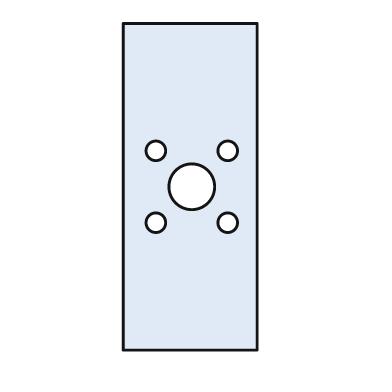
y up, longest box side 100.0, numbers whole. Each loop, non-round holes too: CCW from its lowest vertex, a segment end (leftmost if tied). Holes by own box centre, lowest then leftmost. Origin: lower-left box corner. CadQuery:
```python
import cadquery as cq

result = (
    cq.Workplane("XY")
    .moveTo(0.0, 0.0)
    .lineTo(41.0, 0.0)
    .lineTo(41.0, 100.0)
    .lineTo(0.0, 100.0)
    .close()
    .moveTo(10.0, 39.0)
    .circle(3.0)
    .moveTo(32.0, 39.0)
    .circle(3.0)
    .moveTo(21.0, 50.0)
    .circle(7.0)
    .moveTo(10.0, 61.0)
    .circle(3.0)
    .moveTo(32.0, 61.0)
    .circle(3.0)
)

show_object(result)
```